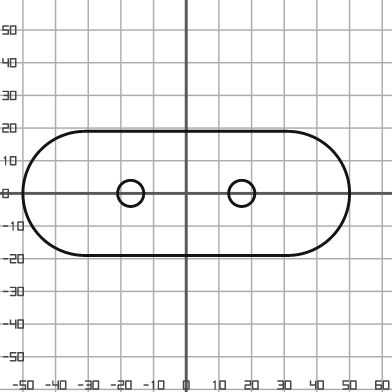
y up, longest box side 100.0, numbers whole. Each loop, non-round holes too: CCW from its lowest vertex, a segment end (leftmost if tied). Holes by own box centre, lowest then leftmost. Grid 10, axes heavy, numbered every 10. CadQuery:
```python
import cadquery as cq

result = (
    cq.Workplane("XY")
    .moveTo(-31.0, -19.0)
    .lineTo(31.0, -19.0)
    .threePointArc((50.0, 0.0), (31.0, 19.0))
    .lineTo(-31.0, 19.0)
    .threePointArc((-50.0, 0.0), (-31.0, -19.0))
    .close()
    .moveTo(-17.0, 0.0)
    .circle(4.0)
    .moveTo(17.0, 0.0)
    .circle(4.0)
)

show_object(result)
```